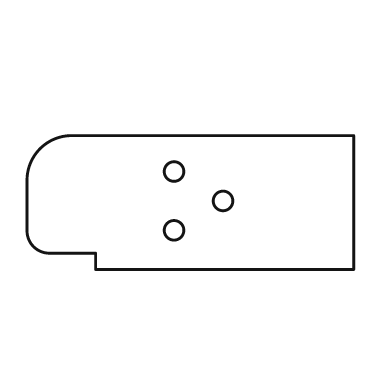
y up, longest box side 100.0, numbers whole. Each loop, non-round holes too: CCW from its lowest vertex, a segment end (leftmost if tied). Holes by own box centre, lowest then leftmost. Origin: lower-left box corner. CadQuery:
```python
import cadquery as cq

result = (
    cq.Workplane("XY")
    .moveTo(21.0, 0.0)
    .lineTo(100.0, 0.0)
    .lineTo(100.0, 41.0)
    .lineTo(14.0, 41.0)
    .threePointArc((4.0, 37.0), (0.0, 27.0))
    .lineTo(0.0, 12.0)
    .threePointArc((2.0, 7.0), (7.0, 5.0))
    .lineTo(21.0, 5.0)
    .close()
    .moveTo(45.0, 12.0)
    .circle(3.0)
    .moveTo(60.0, 21.0)
    .circle(3.0)
    .moveTo(45.0, 30.0)
    .circle(3.0)
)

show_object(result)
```